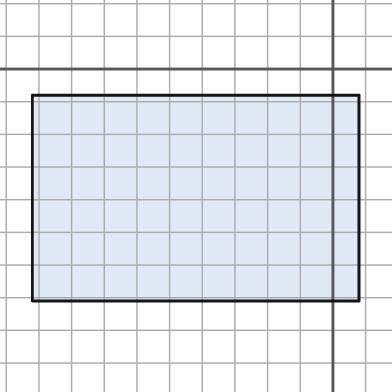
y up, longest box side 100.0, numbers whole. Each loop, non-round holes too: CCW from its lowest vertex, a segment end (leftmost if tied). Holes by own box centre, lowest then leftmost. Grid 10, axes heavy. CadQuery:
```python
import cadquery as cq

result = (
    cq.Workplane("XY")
    .moveTo(-92.0, -71.0)
    .lineTo(8.0, -71.0)
    .lineTo(8.0, -8.0)
    .lineTo(-92.0, -8.0)
    .close()
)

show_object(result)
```